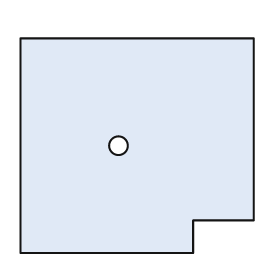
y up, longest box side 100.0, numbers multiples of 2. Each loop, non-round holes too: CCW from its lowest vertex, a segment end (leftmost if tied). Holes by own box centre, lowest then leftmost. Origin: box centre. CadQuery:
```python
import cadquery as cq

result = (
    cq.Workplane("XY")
    .moveTo(-50.0, -46.0)
    .lineTo(24.0, -46.0)
    .lineTo(24.0, -32.0)
    .lineTo(50.0, -32.0)
    .lineTo(50.0, 46.0)
    .lineTo(-50.0, 46.0)
    .close()
    .moveTo(-8.0, 0.0)
    .circle(4.0)
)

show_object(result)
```